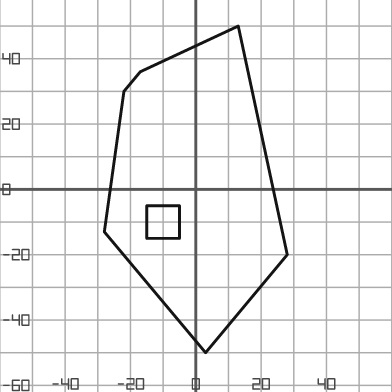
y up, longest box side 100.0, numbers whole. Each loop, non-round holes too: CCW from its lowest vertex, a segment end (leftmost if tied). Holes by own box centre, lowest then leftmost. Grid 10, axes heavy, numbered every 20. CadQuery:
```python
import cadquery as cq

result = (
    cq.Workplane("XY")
    .moveTo(3.0, -50.0)
    .lineTo(28.0, -20.0)
    .lineTo(13.0, 50.0)
    .lineTo(-17.0, 36.0)
    .lineTo(-22.0, 30.0)
    .lineTo(-28.0, -13.0)
    .close()
    .moveTo(-15.0, -15.0)
    .lineTo(-5.0, -15.0)
    .lineTo(-5.0, -5.0)
    .lineTo(-15.0, -5.0)
    .close()
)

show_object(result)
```